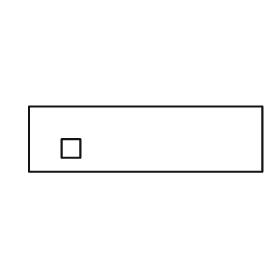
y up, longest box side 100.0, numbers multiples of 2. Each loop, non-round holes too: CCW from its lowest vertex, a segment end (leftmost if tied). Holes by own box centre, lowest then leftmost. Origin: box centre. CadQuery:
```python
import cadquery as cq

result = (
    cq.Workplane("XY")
    .moveTo(-50.0, -14.0)
    .lineTo(50.0, -14.0)
    .lineTo(50.0, 14.0)
    .lineTo(-50.0, 14.0)
    .close()
    .moveTo(-36.0, -8.0)
    .lineTo(-28.0, -8.0)
    .lineTo(-28.0, 0.0)
    .lineTo(-36.0, 0.0)
    .close()
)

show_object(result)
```